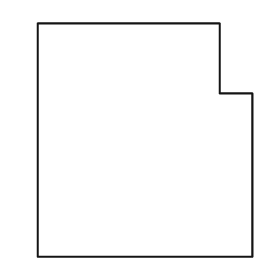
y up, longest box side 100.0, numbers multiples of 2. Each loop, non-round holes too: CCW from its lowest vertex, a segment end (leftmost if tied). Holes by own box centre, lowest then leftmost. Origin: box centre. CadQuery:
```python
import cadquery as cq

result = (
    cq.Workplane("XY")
    .moveTo(-46.0, -50.0)
    .lineTo(46.0, -50.0)
    .lineTo(46.0, 20.0)
    .lineTo(32.0, 20.0)
    .lineTo(32.0, 50.0)
    .lineTo(-46.0, 50.0)
    .close()
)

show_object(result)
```